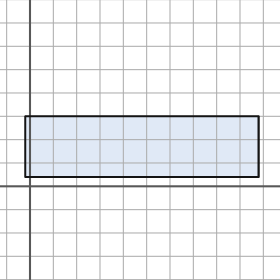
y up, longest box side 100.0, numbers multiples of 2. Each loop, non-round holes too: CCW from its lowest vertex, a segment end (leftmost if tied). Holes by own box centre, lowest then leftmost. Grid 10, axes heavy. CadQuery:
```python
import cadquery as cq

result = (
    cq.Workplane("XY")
    .moveTo(-2.0, 4.0)
    .lineTo(98.0, 4.0)
    .lineTo(98.0, 30.0)
    .lineTo(-2.0, 30.0)
    .close()
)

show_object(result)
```